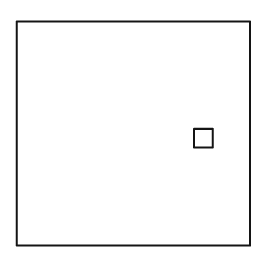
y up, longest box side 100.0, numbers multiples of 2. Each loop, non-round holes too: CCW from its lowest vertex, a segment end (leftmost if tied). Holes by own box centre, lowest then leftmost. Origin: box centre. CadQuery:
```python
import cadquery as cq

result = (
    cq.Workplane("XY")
    .moveTo(-50.0, -48.0)
    .lineTo(50.0, -48.0)
    .lineTo(50.0, 48.0)
    .lineTo(-50.0, 48.0)
    .close()
    .moveTo(26.0, -6.0)
    .lineTo(34.0, -6.0)
    .lineTo(34.0, 2.0)
    .lineTo(26.0, 2.0)
    .close()
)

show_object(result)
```